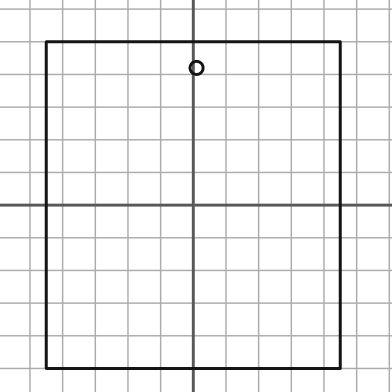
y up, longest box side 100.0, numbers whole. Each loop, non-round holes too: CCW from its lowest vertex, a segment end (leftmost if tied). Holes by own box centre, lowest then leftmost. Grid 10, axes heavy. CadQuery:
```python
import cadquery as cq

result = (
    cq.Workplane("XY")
    .moveTo(-45.0, -50.0)
    .lineTo(45.0, -50.0)
    .lineTo(45.0, 50.0)
    .lineTo(-45.0, 50.0)
    .close()
    .moveTo(1.0, 42.0)
    .circle(2.0)
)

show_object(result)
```